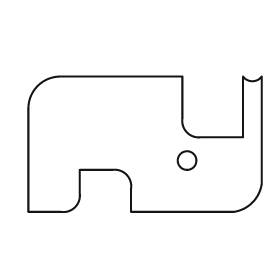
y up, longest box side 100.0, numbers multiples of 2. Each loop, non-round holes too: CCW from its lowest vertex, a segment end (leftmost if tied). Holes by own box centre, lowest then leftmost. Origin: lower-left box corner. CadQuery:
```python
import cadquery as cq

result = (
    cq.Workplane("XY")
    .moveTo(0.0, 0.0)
    .lineTo(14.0, 0.0)
    .threePointArc((20.0, 2.0), (22.0, 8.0))
    .lineTo(22.0, 18.0)
    .lineTo(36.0, 18.0)
    .threePointArc((42.0, 16.0), (44.0, 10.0))
    .lineTo(44.0, 0.0)
    .lineTo(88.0, 0.0)
    .threePointArc((96.0, 4.0), (100.0, 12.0))
    .lineTo(100.0, 58.0)
    .threePointArc((96.0, 56.0), (92.0, 58.0))
    .lineTo(92.0, 32.0)
    .lineTo(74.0, 32.0)
    .threePointArc((68.0, 34.0), (66.0, 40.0))
    .lineTo(66.0, 58.0)
    .lineTo(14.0, 58.0)
    .threePointArc((4.0, 54.0), (0.0, 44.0))
    .close()
    .moveTo(68.0, 22.0)
    .circle(4.0)
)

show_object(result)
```